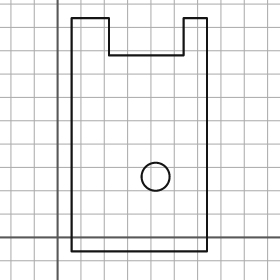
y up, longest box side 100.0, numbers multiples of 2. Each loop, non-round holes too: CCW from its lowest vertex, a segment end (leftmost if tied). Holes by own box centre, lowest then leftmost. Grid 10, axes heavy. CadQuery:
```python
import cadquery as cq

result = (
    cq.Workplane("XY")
    .moveTo(6.0, -6.0)
    .lineTo(64.0, -6.0)
    .lineTo(64.0, 94.0)
    .lineTo(54.0, 94.0)
    .lineTo(54.0, 78.0)
    .lineTo(22.0, 78.0)
    .lineTo(22.0, 94.0)
    .lineTo(6.0, 94.0)
    .close()
    .moveTo(42.0, 26.0)
    .circle(6.0)
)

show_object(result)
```